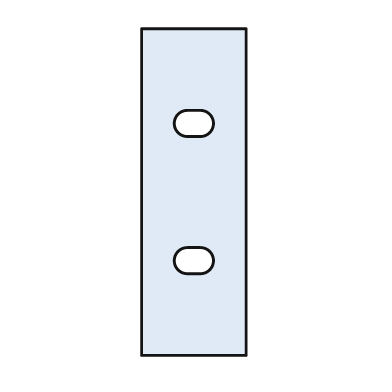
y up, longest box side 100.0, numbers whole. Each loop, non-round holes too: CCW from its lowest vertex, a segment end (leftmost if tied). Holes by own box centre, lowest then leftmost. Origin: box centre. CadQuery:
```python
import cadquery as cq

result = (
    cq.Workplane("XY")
    .moveTo(-16.0, -50.0)
    .lineTo(16.0, -50.0)
    .lineTo(16.0, 50.0)
    .lineTo(-16.0, 50.0)
    .close()
    .moveTo(-2.0, -25.0)
    .lineTo(2.0, -25.0)
    .threePointArc((6.0, -21.0), (2.0, -17.0))
    .lineTo(-2.0, -17.0)
    .threePointArc((-6.0, -21.0), (-2.0, -25.0))
    .close()
    .moveTo(-2.0, 17.0)
    .lineTo(2.0, 17.0)
    .threePointArc((6.0, 21.0), (2.0, 25.0))
    .lineTo(-2.0, 25.0)
    .threePointArc((-6.0, 21.0), (-2.0, 17.0))
    .close()
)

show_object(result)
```